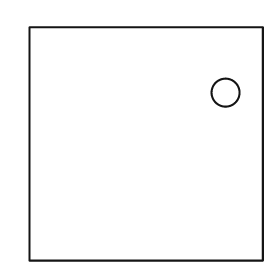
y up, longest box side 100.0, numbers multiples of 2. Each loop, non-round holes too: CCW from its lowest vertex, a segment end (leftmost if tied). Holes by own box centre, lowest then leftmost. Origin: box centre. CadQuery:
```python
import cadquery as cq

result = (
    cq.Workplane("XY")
    .moveTo(-50.0, -50.0)
    .lineTo(50.0, -50.0)
    .lineTo(50.0, 50.0)
    .lineTo(-50.0, 50.0)
    .close()
    .moveTo(34.0, 22.0)
    .circle(6.0)
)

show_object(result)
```